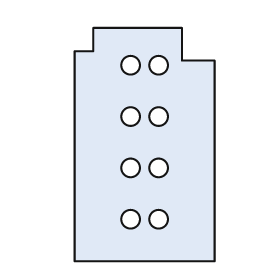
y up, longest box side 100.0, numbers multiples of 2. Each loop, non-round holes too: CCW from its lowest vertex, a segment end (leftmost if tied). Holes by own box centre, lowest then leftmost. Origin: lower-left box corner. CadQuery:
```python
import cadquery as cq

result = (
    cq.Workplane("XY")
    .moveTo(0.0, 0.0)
    .lineTo(60.0, 0.0)
    .lineTo(60.0, 86.0)
    .lineTo(46.0, 86.0)
    .lineTo(46.0, 100.0)
    .lineTo(8.0, 100.0)
    .lineTo(8.0, 90.0)
    .lineTo(0.0, 90.0)
    .close()
    .moveTo(24.0, 18.0)
    .circle(4.0)
    .moveTo(36.0, 18.0)
    .circle(4.0)
    .moveTo(24.0, 40.0)
    .circle(4.0)
    .moveTo(36.0, 40.0)
    .circle(4.0)
    .moveTo(24.0, 62.0)
    .circle(4.0)
    .moveTo(36.0, 62.0)
    .circle(4.0)
    .moveTo(24.0, 84.0)
    .circle(4.0)
    .moveTo(36.0, 84.0)
    .circle(4.0)
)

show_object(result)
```